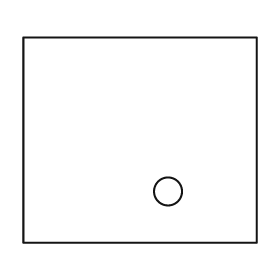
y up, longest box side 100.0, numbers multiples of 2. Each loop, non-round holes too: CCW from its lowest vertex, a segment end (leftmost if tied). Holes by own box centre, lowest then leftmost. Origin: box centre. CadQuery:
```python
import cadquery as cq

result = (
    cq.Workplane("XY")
    .moveTo(-50.0, -44.0)
    .lineTo(50.0, -44.0)
    .lineTo(50.0, 44.0)
    .lineTo(-50.0, 44.0)
    .close()
    .moveTo(12.0, -22.0)
    .circle(6.0)
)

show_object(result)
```